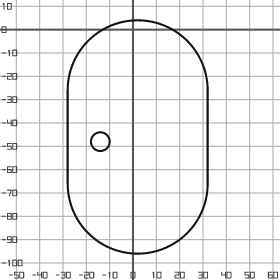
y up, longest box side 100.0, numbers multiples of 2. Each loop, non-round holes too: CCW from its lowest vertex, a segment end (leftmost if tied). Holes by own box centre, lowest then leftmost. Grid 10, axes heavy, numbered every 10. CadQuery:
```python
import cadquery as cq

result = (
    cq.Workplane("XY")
    .moveTo(-28.0, -66.0)
    .threePointArc((2.0, -96.0), (32.0, -66.0))
    .lineTo(32.0, -26.0)
    .threePointArc((2.0, 4.0), (-28.0, -26.0))
    .close()
    .moveTo(-14.0, -48.0)
    .circle(4.0)
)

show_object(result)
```